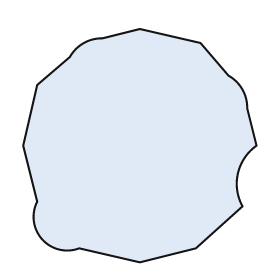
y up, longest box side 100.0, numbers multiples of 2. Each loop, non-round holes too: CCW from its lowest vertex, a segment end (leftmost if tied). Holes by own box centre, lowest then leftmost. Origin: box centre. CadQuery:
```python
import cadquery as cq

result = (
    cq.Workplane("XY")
    .moveTo(0.0, -50.0)
    .lineTo(24.0, -44.0)
    .lineTo(44.0, -26.0)
    .threePointArc((42.0, -12.0), (50.0, 0.0))
    .lineTo(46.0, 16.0)
    .threePointArc((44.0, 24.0), (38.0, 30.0))
    .lineTo(26.0, 44.0)
    .lineTo(0.0, 50.0)
    .lineTo(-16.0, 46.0)
    .threePointArc((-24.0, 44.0), (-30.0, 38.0))
    .lineTo(-44.0, 26.0)
    .lineTo(-50.0, 0.0)
    .lineTo(-44.0, -24.0)
    .threePointArc((-42.0, -40.0), (-26.0, -44.0))
    .close()
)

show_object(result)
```